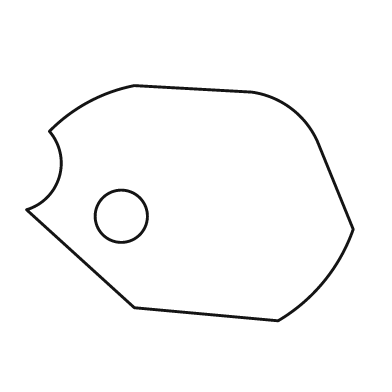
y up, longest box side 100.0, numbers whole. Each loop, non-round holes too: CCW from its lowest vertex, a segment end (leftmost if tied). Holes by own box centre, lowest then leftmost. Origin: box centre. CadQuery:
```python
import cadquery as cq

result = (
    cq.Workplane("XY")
    .moveTo(27.0, -36.0)
    .threePointArc((41.0, -24.0), (50.0, -8.0))
    .lineTo(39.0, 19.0)
    .threePointArc((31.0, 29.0), (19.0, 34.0))
    .lineTo(-17.0, 36.0)
    .threePointArc((-31.0, 31.0), (-43.0, 22.0))
    .threePointArc((-40.0, 8.0), (-50.0, -2.0))
    .lineTo(-17.0, -32.0)
    .close()
    .moveTo(-21.0, -4.0)
    .circle(8.0)
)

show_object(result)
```